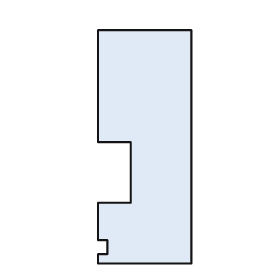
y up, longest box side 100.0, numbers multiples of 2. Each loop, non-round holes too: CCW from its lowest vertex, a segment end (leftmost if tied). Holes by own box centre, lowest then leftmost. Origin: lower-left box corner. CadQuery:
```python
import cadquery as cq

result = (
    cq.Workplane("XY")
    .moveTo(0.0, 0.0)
    .lineTo(40.0, 0.0)
    .lineTo(40.0, 100.0)
    .lineTo(0.0, 100.0)
    .lineTo(0.0, 52.0)
    .lineTo(14.0, 52.0)
    .lineTo(14.0, 26.0)
    .lineTo(0.0, 26.0)
    .lineTo(0.0, 10.0)
    .lineTo(4.0, 10.0)
    .lineTo(4.0, 4.0)
    .lineTo(0.0, 4.0)
    .close()
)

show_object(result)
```